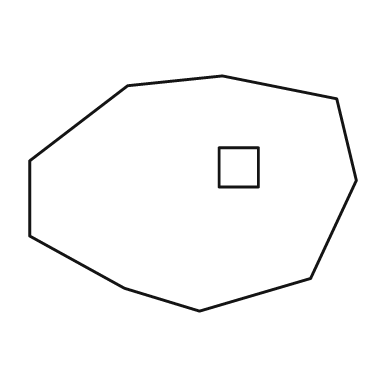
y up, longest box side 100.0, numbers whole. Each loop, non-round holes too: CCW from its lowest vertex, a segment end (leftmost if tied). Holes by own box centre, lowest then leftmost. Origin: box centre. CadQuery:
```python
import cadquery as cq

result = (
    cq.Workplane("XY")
    .moveTo(2.0, -36.0)
    .lineTo(36.0, -26.0)
    .lineTo(50.0, 4.0)
    .lineTo(44.0, 29.0)
    .lineTo(9.0, 36.0)
    .lineTo(-20.0, 33.0)
    .lineTo(-50.0, 10.0)
    .lineTo(-50.0, -13.0)
    .lineTo(-21.0, -29.0)
    .close()
    .moveTo(8.0, 2.0)
    .lineTo(20.0, 2.0)
    .lineTo(20.0, 14.0)
    .lineTo(8.0, 14.0)
    .close()
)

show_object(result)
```